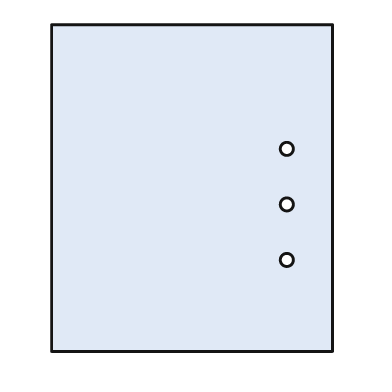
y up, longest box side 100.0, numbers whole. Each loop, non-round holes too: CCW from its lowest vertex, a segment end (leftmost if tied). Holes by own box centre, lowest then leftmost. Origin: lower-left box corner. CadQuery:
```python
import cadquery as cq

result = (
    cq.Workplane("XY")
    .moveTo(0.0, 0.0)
    .lineTo(86.0, 0.0)
    .lineTo(86.0, 100.0)
    .lineTo(0.0, 100.0)
    .close()
    .moveTo(72.0, 28.0)
    .circle(2.0)
    .moveTo(72.0, 45.0)
    .circle(2.0)
    .moveTo(72.0, 62.0)
    .circle(2.0)
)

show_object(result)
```